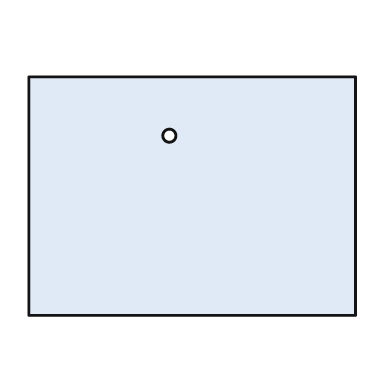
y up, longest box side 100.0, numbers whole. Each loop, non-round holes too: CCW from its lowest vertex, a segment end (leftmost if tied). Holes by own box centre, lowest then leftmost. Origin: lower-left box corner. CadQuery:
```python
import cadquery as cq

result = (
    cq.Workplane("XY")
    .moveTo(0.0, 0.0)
    .lineTo(100.0, 0.0)
    .lineTo(100.0, 73.0)
    .lineTo(0.0, 73.0)
    .close()
    .moveTo(43.0, 55.0)
    .circle(2.0)
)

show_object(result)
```